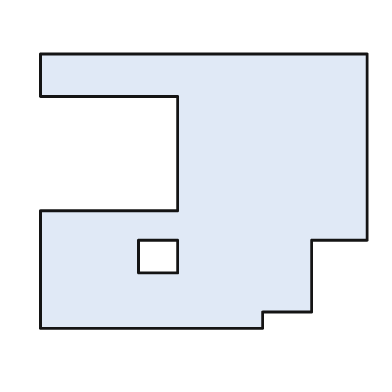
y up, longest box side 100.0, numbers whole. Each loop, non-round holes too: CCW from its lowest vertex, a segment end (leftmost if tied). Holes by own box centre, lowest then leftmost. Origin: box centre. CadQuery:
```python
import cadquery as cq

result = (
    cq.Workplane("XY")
    .moveTo(-50.0, -42.0)
    .lineTo(18.0, -42.0)
    .lineTo(18.0, -37.0)
    .lineTo(33.0, -37.0)
    .lineTo(33.0, -15.0)
    .lineTo(50.0, -15.0)
    .lineTo(50.0, 42.0)
    .lineTo(-50.0, 42.0)
    .lineTo(-50.0, 29.0)
    .lineTo(-8.0, 29.0)
    .lineTo(-8.0, -6.0)
    .lineTo(-50.0, -6.0)
    .close()
    .moveTo(-20.0, -25.0)
    .lineTo(-8.0, -25.0)
    .lineTo(-8.0, -15.0)
    .lineTo(-20.0, -15.0)
    .close()
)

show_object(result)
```